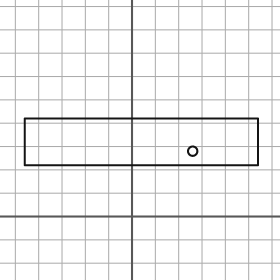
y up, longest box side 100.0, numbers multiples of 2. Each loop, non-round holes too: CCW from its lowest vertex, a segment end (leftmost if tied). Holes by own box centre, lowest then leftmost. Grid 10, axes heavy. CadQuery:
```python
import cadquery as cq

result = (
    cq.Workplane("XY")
    .moveTo(-46.0, 22.0)
    .lineTo(54.0, 22.0)
    .lineTo(54.0, 42.0)
    .lineTo(-46.0, 42.0)
    .close()
    .moveTo(26.0, 28.0)
    .circle(2.0)
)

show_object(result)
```